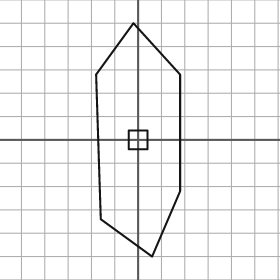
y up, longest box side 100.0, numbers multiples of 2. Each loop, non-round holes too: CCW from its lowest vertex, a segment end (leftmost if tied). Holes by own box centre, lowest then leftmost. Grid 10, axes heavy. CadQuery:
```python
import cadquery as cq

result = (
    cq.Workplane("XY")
    .moveTo(6.0, -50.0)
    .lineTo(18.0, -22.0)
    .lineTo(18.0, 28.0)
    .lineTo(-2.0, 50.0)
    .lineTo(-18.0, 28.0)
    .lineTo(-16.0, -34.0)
    .close()
    .moveTo(-4.0, -4.0)
    .lineTo(4.0, -4.0)
    .lineTo(4.0, 4.0)
    .lineTo(-4.0, 4.0)
    .close()
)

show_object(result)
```